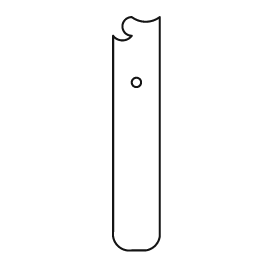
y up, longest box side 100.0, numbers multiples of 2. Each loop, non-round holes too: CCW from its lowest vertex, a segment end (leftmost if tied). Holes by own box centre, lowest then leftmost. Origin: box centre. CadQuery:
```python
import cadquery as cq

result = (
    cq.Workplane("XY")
    .moveTo(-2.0, -50.0)
    .lineTo(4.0, -50.0)
    .threePointArc((8.0, -48.0), (10.0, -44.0))
    .lineTo(10.0, 50.0)
    .threePointArc((4.0, 48.0), (-2.0, 50.0))
    .threePointArc((-6.0, 46.0), (-2.0, 42.0))
    .threePointArc((-6.0, 40.0), (-10.0, 42.0))
    .lineTo(-10.0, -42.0)
    .threePointArc((-8.0, -48.0), (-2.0, -50.0))
    .close()
    .moveTo(0.0, 22.0)
    .circle(2.0)
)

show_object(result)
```